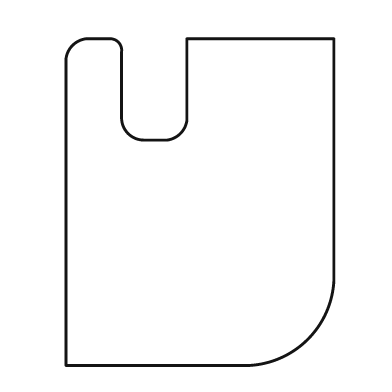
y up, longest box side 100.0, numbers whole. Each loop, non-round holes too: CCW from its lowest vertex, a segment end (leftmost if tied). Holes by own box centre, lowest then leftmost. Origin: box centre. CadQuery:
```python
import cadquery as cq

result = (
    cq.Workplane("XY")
    .moveTo(-41.0, -50.0)
    .lineTo(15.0, -50.0)
    .threePointArc((33.0, -42.0), (41.0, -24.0))
    .lineTo(41.0, 50.0)
    .lineTo(-4.0, 50.0)
    .lineTo(-4.0, 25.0)
    .threePointArc((-6.0, 21.0), (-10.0, 19.0))
    .lineTo(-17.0, 19.0)
    .threePointArc((-22.0, 21.0), (-24.0, 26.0))
    .lineTo(-24.0, 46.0)
    .threePointArc((-25.0, 49.0), (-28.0, 50.0))
    .lineTo(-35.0, 50.0)
    .threePointArc((-39.0, 48.0), (-41.0, 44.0))
    .close()
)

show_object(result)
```